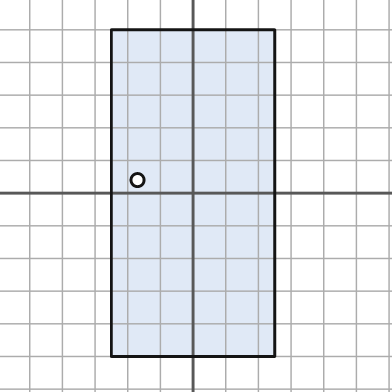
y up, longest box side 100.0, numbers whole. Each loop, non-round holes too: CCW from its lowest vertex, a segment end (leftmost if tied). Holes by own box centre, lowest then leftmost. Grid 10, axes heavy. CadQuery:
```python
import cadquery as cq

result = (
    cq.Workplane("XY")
    .moveTo(-25.0, -50.0)
    .lineTo(25.0, -50.0)
    .lineTo(25.0, 50.0)
    .lineTo(-25.0, 50.0)
    .close()
    .moveTo(-17.0, 4.0)
    .circle(2.0)
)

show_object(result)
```